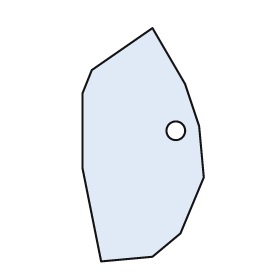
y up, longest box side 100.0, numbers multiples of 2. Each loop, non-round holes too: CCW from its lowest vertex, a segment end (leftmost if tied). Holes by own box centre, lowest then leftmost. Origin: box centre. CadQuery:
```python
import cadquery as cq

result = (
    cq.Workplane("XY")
    .moveTo(-18.0, -50.0)
    .lineTo(4.0, -48.0)
    .lineTo(16.0, -38.0)
    .lineTo(26.0, -14.0)
    .lineTo(24.0, 8.0)
    .lineTo(18.0, 26.0)
    .lineTo(4.0, 50.0)
    .lineTo(-22.0, 32.0)
    .lineTo(-26.0, 22.0)
    .lineTo(-26.0, -10.0)
    .close()
    .moveTo(14.0, 6.0)
    .circle(4.0)
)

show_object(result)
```